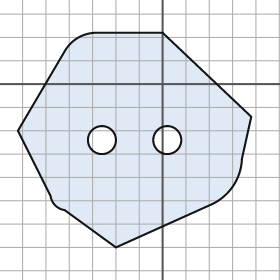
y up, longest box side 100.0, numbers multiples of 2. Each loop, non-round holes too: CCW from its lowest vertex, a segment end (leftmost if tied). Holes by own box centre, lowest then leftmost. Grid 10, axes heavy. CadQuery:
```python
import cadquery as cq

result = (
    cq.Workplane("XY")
    .moveTo(-20.0, -70.0)
    .lineTo(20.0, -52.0)
    .threePointArc((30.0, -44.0), (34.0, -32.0))
    .lineTo(38.0, -14.0)
    .lineTo(0.0, 22.0)
    .lineTo(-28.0, 22.0)
    .threePointArc((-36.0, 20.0), (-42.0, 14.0))
    .lineTo(-62.0, -20.0)
    .lineTo(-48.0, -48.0)
    .threePointArc((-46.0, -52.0), (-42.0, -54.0))
    .close()
    .moveTo(-26.0, -24.0)
    .circle(6.0)
    .moveTo(2.0, -24.0)
    .circle(6.0)
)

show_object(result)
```